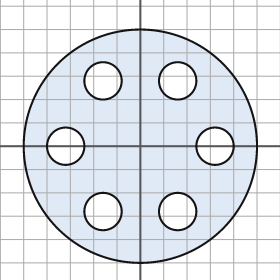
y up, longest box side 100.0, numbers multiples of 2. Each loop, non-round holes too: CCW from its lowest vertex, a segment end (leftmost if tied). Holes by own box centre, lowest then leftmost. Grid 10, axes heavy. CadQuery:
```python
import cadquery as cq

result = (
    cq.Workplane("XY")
    .moveTo(0.0, 0.0)
    .circle(50.0)
    .moveTo(-16.0, -28.0)
    .circle(8.0)
    .moveTo(16.0, -28.0)
    .circle(8.0)
    .moveTo(-32.0, 0.0)
    .circle(8.0)
    .moveTo(32.0, 0.0)
    .circle(8.0)
    .moveTo(-16.0, 28.0)
    .circle(8.0)
    .moveTo(16.0, 28.0)
    .circle(8.0)
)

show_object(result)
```